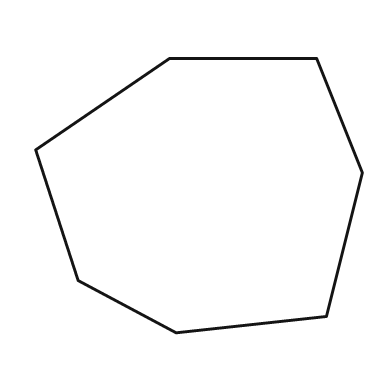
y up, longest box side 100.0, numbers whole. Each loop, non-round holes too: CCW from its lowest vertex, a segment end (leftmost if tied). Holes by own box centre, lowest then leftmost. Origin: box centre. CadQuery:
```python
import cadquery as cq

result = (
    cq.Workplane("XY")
    .moveTo(-7.0, -42.0)
    .lineTo(39.0, -37.0)
    .lineTo(50.0, 7.0)
    .lineTo(36.0, 42.0)
    .lineTo(-9.0, 42.0)
    .lineTo(-50.0, 14.0)
    .lineTo(-37.0, -26.0)
    .close()
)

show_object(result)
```